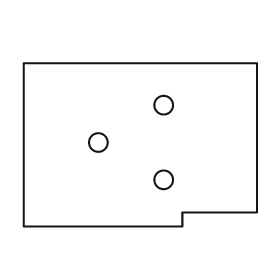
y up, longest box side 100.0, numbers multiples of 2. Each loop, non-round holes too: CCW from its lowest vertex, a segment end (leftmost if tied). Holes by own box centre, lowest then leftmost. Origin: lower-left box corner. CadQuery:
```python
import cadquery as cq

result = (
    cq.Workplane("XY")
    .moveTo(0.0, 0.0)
    .lineTo(68.0, 0.0)
    .lineTo(68.0, 6.0)
    .lineTo(100.0, 6.0)
    .lineTo(100.0, 70.0)
    .lineTo(0.0, 70.0)
    .close()
    .moveTo(60.0, 20.0)
    .circle(4.0)
    .moveTo(32.0, 36.0)
    .circle(4.0)
    .moveTo(60.0, 52.0)
    .circle(4.0)
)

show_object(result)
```